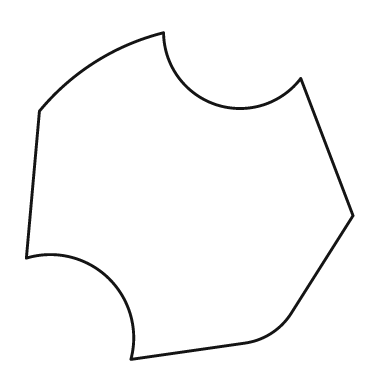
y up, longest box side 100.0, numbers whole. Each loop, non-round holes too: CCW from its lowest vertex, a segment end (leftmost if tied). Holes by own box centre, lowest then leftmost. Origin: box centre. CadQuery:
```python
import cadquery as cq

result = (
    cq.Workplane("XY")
    .moveTo(-18.0, -50.0)
    .lineTo(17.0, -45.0)
    .threePointArc((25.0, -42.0), (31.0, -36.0))
    .lineTo(50.0, -6.0)
    .lineTo(34.0, 36.0)
    .threePointArc((8.0, 28.0), (-8.0, 50.0))
    .threePointArc((-29.0, 41.0), (-46.0, 26.0))
    .lineTo(-50.0, -19.0)
    .threePointArc((-25.0, -25.0), (-18.0, -50.0))
    .close()
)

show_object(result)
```